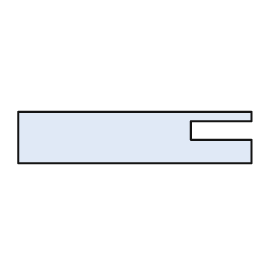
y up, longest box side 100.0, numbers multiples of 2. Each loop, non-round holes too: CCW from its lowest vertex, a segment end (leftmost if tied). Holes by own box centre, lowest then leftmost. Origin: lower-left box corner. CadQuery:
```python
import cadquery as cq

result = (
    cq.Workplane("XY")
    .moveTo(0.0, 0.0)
    .lineTo(100.0, 0.0)
    .lineTo(100.0, 10.0)
    .lineTo(74.0, 10.0)
    .lineTo(74.0, 18.0)
    .lineTo(100.0, 18.0)
    .lineTo(100.0, 22.0)
    .lineTo(0.0, 22.0)
    .close()
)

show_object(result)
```